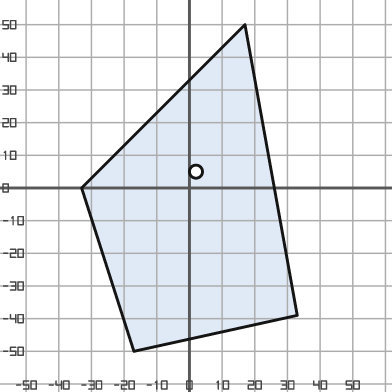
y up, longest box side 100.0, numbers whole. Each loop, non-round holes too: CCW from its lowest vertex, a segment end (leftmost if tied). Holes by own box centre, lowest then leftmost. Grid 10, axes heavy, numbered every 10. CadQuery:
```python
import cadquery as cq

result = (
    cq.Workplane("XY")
    .moveTo(-17.0, -50.0)
    .lineTo(33.0, -39.0)
    .lineTo(17.0, 50.0)
    .lineTo(-33.0, 0.0)
    .close()
    .moveTo(2.0, 5.0)
    .circle(2.0)
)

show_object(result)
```